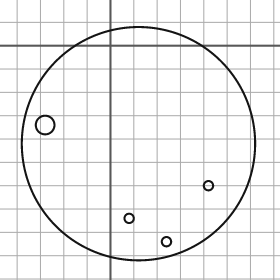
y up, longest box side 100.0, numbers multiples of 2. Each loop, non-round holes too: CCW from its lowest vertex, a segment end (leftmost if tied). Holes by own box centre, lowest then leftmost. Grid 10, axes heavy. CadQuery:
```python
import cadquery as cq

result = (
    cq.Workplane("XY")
    .moveTo(12.0, -42.0)
    .circle(50.0)
    .moveTo(24.0, -84.0)
    .circle(2.0)
    .moveTo(8.0, -74.0)
    .circle(2.0)
    .moveTo(42.0, -60.0)
    .circle(2.0)
    .moveTo(-28.0, -34.0)
    .circle(4.0)
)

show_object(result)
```